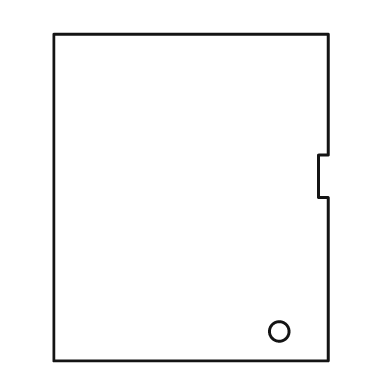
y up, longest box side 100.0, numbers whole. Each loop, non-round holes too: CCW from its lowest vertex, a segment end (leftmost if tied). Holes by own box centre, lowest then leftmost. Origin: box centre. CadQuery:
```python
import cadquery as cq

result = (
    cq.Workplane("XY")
    .moveTo(-42.0, -50.0)
    .lineTo(42.0, -50.0)
    .lineTo(42.0, 0.0)
    .lineTo(39.0, 0.0)
    .lineTo(39.0, 13.0)
    .lineTo(42.0, 13.0)
    .lineTo(42.0, 50.0)
    .lineTo(-42.0, 50.0)
    .close()
    .moveTo(27.0, -41.0)
    .circle(3.0)
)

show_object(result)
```